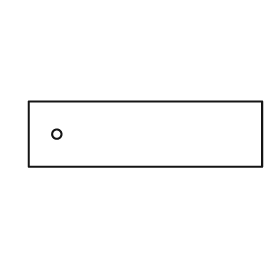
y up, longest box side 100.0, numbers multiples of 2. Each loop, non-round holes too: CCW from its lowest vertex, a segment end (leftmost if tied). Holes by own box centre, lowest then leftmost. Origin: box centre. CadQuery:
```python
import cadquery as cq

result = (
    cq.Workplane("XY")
    .moveTo(-50.0, -14.0)
    .lineTo(50.0, -14.0)
    .lineTo(50.0, 14.0)
    .lineTo(-50.0, 14.0)
    .close()
    .moveTo(-38.0, 0.0)
    .circle(2.0)
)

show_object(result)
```